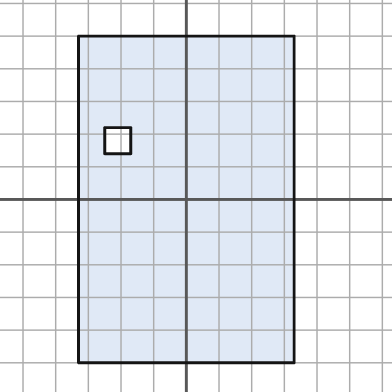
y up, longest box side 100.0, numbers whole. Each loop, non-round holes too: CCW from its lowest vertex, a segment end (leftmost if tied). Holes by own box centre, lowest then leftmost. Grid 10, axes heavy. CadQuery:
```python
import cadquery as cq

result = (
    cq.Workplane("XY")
    .moveTo(-33.0, -50.0)
    .lineTo(33.0, -50.0)
    .lineTo(33.0, 50.0)
    .lineTo(-33.0, 50.0)
    .close()
    .moveTo(-25.0, 14.0)
    .lineTo(-17.0, 14.0)
    .lineTo(-17.0, 22.0)
    .lineTo(-25.0, 22.0)
    .close()
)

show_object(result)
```